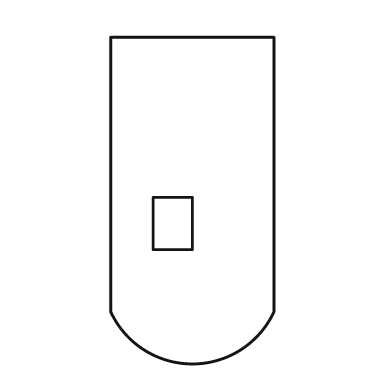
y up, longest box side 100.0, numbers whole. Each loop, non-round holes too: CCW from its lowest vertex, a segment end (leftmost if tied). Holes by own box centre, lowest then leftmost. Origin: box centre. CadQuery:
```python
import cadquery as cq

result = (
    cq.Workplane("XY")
    .moveTo(-25.0, -34.0)
    .threePointArc((0.0, -50.0), (25.0, -34.0))
    .lineTo(25.0, 50.0)
    .lineTo(-25.0, 50.0)
    .close()
    .moveTo(-12.0, -15.0)
    .lineTo(0.0, -15.0)
    .lineTo(0.0, 1.0)
    .lineTo(-12.0, 1.0)
    .close()
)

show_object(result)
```